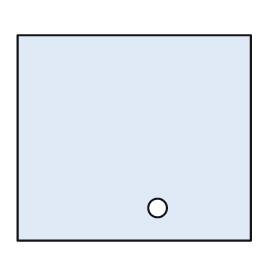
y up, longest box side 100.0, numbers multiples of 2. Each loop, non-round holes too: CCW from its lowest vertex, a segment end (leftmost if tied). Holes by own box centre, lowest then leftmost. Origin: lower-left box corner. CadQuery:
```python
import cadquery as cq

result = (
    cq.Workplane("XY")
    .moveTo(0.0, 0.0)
    .lineTo(100.0, 0.0)
    .lineTo(100.0, 88.0)
    .lineTo(0.0, 88.0)
    .close()
    .moveTo(60.0, 14.0)
    .circle(4.0)
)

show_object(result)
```